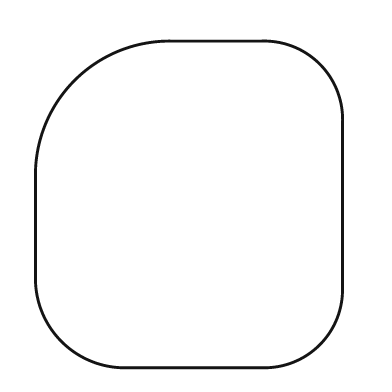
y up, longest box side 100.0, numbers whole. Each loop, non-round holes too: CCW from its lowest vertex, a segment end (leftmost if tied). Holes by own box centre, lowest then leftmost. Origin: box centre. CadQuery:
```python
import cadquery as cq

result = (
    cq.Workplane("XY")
    .moveTo(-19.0, -50.0)
    .lineTo(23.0, -50.0)
    .threePointArc((40.0, -43.0), (47.0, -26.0))
    .lineTo(47.0, 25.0)
    .threePointArc((40.0, 43.0), (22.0, 50.0))
    .lineTo(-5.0, 50.0)
    .threePointArc((-35.0, 38.0), (-47.0, 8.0))
    .lineTo(-47.0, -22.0)
    .threePointArc((-39.0, -42.0), (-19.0, -50.0))
    .close()
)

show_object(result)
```